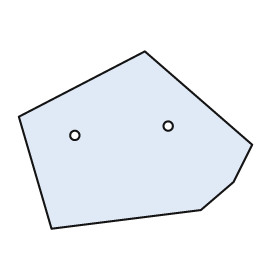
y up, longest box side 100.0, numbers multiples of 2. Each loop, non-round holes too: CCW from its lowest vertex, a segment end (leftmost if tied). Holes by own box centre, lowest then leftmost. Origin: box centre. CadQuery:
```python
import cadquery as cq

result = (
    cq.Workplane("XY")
    .moveTo(-36.0, -38.0)
    .lineTo(28.0, -30.0)
    .lineTo(42.0, -18.0)
    .lineTo(50.0, -2.0)
    .lineTo(4.0, 38.0)
    .lineTo(-50.0, 10.0)
    .close()
    .moveTo(-26.0, 2.0)
    .circle(2.0)
    .moveTo(14.0, 6.0)
    .circle(2.0)
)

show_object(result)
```